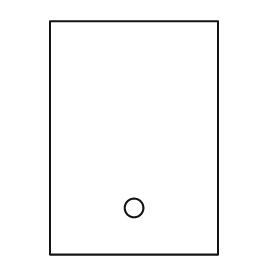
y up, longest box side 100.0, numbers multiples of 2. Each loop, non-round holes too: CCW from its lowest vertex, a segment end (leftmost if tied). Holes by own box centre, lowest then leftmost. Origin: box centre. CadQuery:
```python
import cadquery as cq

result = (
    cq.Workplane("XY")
    .moveTo(-36.0, -50.0)
    .lineTo(36.0, -50.0)
    .lineTo(36.0, 50.0)
    .lineTo(-36.0, 50.0)
    .close()
    .moveTo(0.0, -30.0)
    .circle(4.0)
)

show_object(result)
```